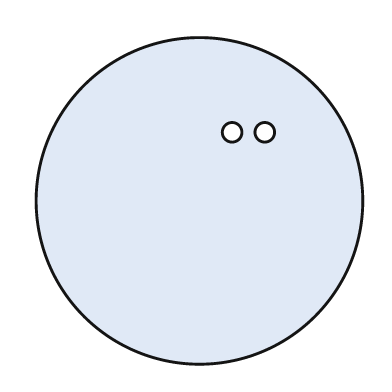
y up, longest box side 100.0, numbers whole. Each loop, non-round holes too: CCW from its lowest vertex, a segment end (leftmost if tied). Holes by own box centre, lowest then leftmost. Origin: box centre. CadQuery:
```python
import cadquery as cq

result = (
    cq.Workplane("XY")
    .moveTo(0.0, 0.0)
    .circle(50.0)
    .moveTo(10.0, 21.0)
    .circle(3.0)
    .moveTo(20.0, 21.0)
    .circle(3.0)
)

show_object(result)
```